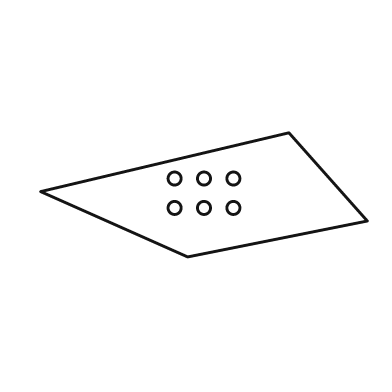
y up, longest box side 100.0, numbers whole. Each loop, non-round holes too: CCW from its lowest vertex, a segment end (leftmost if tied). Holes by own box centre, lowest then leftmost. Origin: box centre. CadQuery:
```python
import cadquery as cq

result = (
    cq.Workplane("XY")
    .moveTo(-5.0, -19.0)
    .lineTo(50.0, -8.0)
    .lineTo(26.0, 19.0)
    .lineTo(-50.0, 1.0)
    .close()
    .moveTo(-9.0, -4.0)
    .circle(2.0)
    .moveTo(0.0, -4.0)
    .circle(2.0)
    .moveTo(9.0, -4.0)
    .circle(2.0)
    .moveTo(-9.0, 5.0)
    .circle(2.0)
    .moveTo(0.0, 5.0)
    .circle(2.0)
    .moveTo(9.0, 5.0)
    .circle(2.0)
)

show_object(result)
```